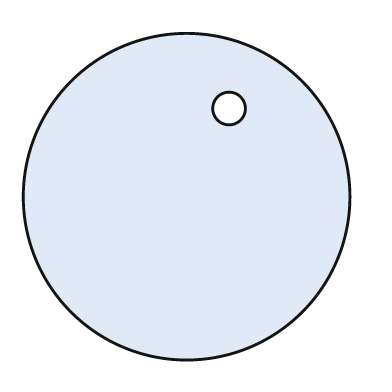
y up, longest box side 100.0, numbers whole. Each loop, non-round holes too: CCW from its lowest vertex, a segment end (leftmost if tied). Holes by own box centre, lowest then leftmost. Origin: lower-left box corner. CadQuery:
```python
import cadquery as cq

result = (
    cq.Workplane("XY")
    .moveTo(50.0, 50.0)
    .circle(50.0)
    .moveTo(63.0, 77.0)
    .circle(5.0)
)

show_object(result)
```